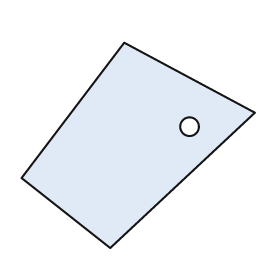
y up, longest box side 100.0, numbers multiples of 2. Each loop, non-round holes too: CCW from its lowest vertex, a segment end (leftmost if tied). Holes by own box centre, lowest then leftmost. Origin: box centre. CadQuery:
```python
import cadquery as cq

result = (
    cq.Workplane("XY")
    .moveTo(-12.0, -44.0)
    .lineTo(50.0, 14.0)
    .lineTo(-6.0, 44.0)
    .lineTo(-50.0, -14.0)
    .close()
    .moveTo(22.0, 8.0)
    .circle(4.0)
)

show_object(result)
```